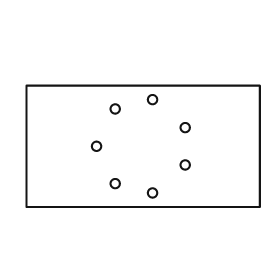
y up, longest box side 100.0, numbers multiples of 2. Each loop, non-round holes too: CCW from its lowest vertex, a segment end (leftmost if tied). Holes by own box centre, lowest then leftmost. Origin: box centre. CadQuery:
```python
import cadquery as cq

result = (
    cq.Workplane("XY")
    .moveTo(-50.0, -26.0)
    .lineTo(50.0, -26.0)
    .lineTo(50.0, 26.0)
    .lineTo(-50.0, 26.0)
    .close()
    .moveTo(4.0, -20.0)
    .circle(2.0)
    .moveTo(-12.0, -16.0)
    .circle(2.0)
    .moveTo(18.0, -8.0)
    .circle(2.0)
    .moveTo(-20.0, 0.0)
    .circle(2.0)
    .moveTo(18.0, 8.0)
    .circle(2.0)
    .moveTo(-12.0, 16.0)
    .circle(2.0)
    .moveTo(4.0, 20.0)
    .circle(2.0)
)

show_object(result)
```